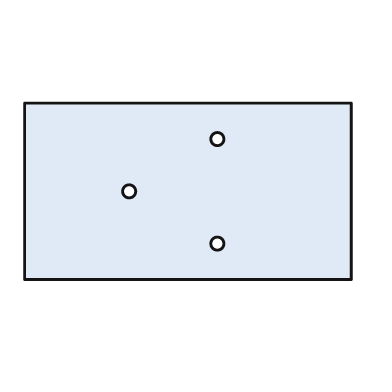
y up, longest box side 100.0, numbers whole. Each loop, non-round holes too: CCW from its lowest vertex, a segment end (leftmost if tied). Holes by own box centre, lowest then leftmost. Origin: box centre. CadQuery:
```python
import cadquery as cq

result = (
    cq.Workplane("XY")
    .moveTo(-50.0, -27.0)
    .lineTo(50.0, -27.0)
    .lineTo(50.0, 27.0)
    .lineTo(-50.0, 27.0)
    .close()
    .moveTo(9.0, -16.0)
    .circle(2.0)
    .moveTo(-18.0, 0.0)
    .circle(2.0)
    .moveTo(9.0, 16.0)
    .circle(2.0)
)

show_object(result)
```